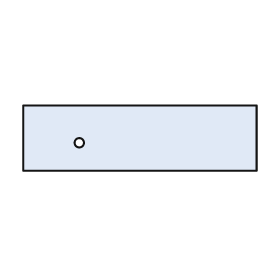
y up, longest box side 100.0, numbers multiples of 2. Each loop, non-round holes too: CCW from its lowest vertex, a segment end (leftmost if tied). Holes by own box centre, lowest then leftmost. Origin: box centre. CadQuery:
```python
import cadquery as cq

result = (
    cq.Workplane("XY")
    .moveTo(-50.0, -14.0)
    .lineTo(50.0, -14.0)
    .lineTo(50.0, 14.0)
    .lineTo(-50.0, 14.0)
    .close()
    .moveTo(-26.0, -2.0)
    .circle(2.0)
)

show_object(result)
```